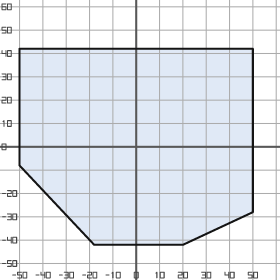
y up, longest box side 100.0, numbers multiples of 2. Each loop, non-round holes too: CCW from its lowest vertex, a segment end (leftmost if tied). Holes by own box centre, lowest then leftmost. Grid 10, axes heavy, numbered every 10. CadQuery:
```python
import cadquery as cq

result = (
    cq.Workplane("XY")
    .moveTo(-18.0, -42.0)
    .lineTo(20.0, -42.0)
    .lineTo(50.0, -28.0)
    .lineTo(50.0, 42.0)
    .lineTo(-50.0, 42.0)
    .lineTo(-50.0, -8.0)
    .close()
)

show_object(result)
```